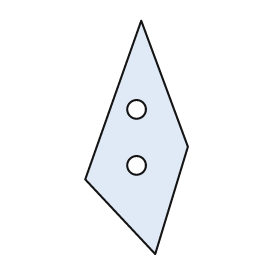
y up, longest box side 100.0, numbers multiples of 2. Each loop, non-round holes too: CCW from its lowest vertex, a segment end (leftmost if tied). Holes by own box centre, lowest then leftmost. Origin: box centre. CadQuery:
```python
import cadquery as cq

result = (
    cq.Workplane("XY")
    .moveTo(8.0, -50.0)
    .lineTo(22.0, -4.0)
    .lineTo(2.0, 50.0)
    .lineTo(-22.0, -18.0)
    .close()
    .moveTo(0.0, -12.0)
    .circle(4.0)
    .moveTo(0.0, 12.0)
    .circle(4.0)
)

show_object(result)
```